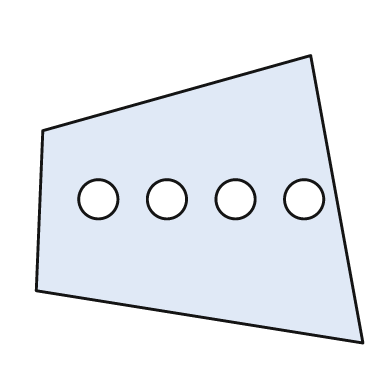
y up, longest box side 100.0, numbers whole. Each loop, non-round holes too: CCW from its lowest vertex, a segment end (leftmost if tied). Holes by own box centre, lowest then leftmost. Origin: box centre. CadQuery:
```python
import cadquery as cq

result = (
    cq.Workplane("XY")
    .moveTo(50.0, -44.0)
    .lineTo(34.0, 44.0)
    .lineTo(-48.0, 21.0)
    .lineTo(-50.0, -28.0)
    .close()
    .moveTo(-31.0, 0.0)
    .circle(6.0)
    .moveTo(-10.0, 0.0)
    .circle(6.0)
    .moveTo(11.0, 0.0)
    .circle(6.0)
    .moveTo(32.0, 0.0)
    .circle(6.0)
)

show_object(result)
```